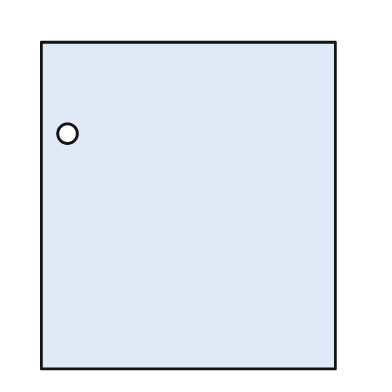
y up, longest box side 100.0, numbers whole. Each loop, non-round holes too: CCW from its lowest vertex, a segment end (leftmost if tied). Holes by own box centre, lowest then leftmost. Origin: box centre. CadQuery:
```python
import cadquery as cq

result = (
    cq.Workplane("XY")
    .moveTo(-45.0, -50.0)
    .lineTo(45.0, -50.0)
    .lineTo(45.0, 50.0)
    .lineTo(-45.0, 50.0)
    .close()
    .moveTo(-37.0, 22.0)
    .circle(3.0)
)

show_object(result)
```